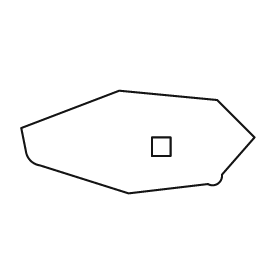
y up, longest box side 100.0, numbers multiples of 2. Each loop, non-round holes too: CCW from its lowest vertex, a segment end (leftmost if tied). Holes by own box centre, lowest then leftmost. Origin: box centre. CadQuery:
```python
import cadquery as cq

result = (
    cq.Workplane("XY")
    .moveTo(-4.0, -22.0)
    .lineTo(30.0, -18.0)
    .threePointArc((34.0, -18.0), (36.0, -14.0))
    .lineTo(50.0, 2.0)
    .lineTo(34.0, 18.0)
    .lineTo(-8.0, 22.0)
    .lineTo(-50.0, 6.0)
    .lineTo(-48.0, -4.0)
    .threePointArc((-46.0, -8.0), (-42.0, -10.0))
    .close()
    .moveTo(6.0, -6.0)
    .lineTo(14.0, -6.0)
    .lineTo(14.0, 2.0)
    .lineTo(6.0, 2.0)
    .close()
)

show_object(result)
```